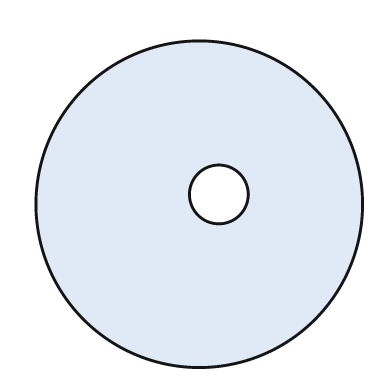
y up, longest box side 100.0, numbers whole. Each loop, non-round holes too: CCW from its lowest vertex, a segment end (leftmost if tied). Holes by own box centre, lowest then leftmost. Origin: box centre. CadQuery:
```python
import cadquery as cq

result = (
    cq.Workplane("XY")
    .moveTo(0.0, 0.0)
    .circle(50.0)
    .moveTo(6.0, 3.0)
    .circle(9.0)
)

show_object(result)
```